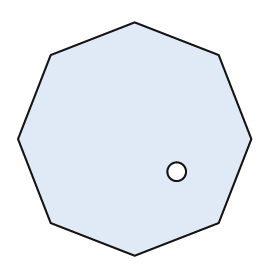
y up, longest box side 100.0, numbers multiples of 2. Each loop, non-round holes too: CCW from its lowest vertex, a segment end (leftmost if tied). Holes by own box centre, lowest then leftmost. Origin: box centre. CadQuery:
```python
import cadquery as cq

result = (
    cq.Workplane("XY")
    .moveTo(0.0, -50.0)
    .lineTo(36.0, -36.0)
    .lineTo(50.0, 0.0)
    .lineTo(36.0, 36.0)
    .lineTo(0.0, 50.0)
    .lineTo(-36.0, 36.0)
    .lineTo(-50.0, 0.0)
    .lineTo(-36.0, -36.0)
    .close()
    .moveTo(18.0, -14.0)
    .circle(4.0)
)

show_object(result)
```